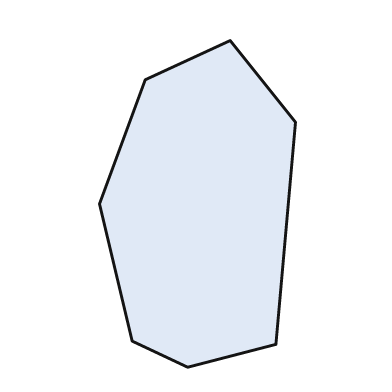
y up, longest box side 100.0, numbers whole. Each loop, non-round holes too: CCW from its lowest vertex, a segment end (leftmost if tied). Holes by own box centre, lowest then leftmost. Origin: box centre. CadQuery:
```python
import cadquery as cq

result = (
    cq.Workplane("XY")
    .moveTo(-3.0, -50.0)
    .lineTo(24.0, -43.0)
    .lineTo(30.0, 25.0)
    .lineTo(10.0, 50.0)
    .lineTo(-16.0, 38.0)
    .lineTo(-30.0, 0.0)
    .lineTo(-20.0, -42.0)
    .close()
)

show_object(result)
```